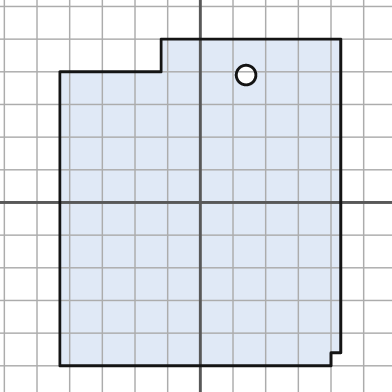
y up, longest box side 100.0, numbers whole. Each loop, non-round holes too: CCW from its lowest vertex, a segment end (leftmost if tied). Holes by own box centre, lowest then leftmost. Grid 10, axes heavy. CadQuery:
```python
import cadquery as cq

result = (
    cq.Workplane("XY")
    .moveTo(-43.0, -50.0)
    .lineTo(40.0, -50.0)
    .lineTo(40.0, -46.0)
    .lineTo(43.0, -46.0)
    .lineTo(43.0, 50.0)
    .lineTo(-12.0, 50.0)
    .lineTo(-12.0, 40.0)
    .lineTo(-43.0, 40.0)
    .close()
    .moveTo(14.0, 39.0)
    .circle(3.0)
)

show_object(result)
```